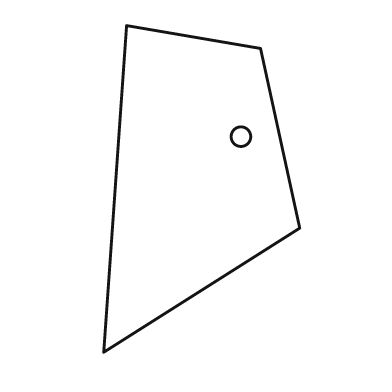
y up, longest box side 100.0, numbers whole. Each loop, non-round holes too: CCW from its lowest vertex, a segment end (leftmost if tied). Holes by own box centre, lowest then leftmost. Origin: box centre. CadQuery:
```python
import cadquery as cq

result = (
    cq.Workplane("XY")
    .moveTo(-30.0, -50.0)
    .lineTo(30.0, -12.0)
    .lineTo(18.0, 43.0)
    .lineTo(-23.0, 50.0)
    .close()
    .moveTo(12.0, 16.0)
    .circle(3.0)
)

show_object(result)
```